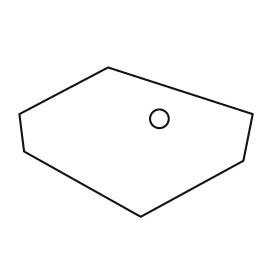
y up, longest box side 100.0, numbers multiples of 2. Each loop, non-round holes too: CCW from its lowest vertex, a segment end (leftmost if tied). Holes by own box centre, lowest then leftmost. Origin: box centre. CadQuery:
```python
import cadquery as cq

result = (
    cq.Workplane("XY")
    .moveTo(2.0, -32.0)
    .lineTo(46.0, -8.0)
    .lineTo(50.0, 12.0)
    .lineTo(-12.0, 32.0)
    .lineTo(-50.0, 12.0)
    .lineTo(-48.0, -4.0)
    .close()
    .moveTo(10.0, 10.0)
    .circle(4.0)
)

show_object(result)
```